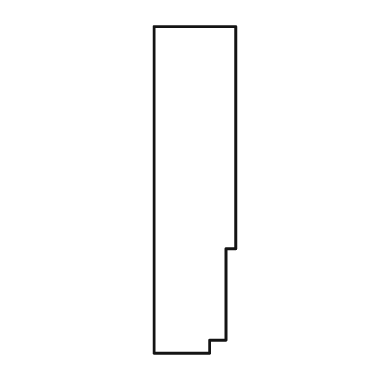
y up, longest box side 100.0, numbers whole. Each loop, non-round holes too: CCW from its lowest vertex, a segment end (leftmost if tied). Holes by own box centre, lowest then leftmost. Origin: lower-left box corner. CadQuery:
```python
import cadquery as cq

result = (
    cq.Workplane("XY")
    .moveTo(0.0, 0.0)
    .lineTo(17.0, 0.0)
    .lineTo(17.0, 4.0)
    .lineTo(22.0, 4.0)
    .lineTo(22.0, 32.0)
    .lineTo(25.0, 32.0)
    .lineTo(25.0, 100.0)
    .lineTo(0.0, 100.0)
    .close()
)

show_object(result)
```